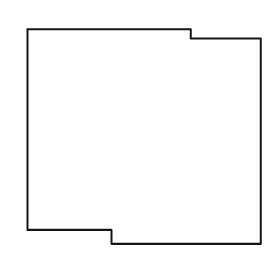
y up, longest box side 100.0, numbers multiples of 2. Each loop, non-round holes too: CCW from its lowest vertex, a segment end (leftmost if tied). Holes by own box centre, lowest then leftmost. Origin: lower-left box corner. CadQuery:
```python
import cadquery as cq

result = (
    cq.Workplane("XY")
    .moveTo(36.0, 0.0)
    .lineTo(100.0, 0.0)
    .lineTo(100.0, 88.0)
    .lineTo(70.0, 88.0)
    .lineTo(70.0, 92.0)
    .lineTo(0.0, 92.0)
    .lineTo(0.0, 6.0)
    .lineTo(36.0, 6.0)
    .close()
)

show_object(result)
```